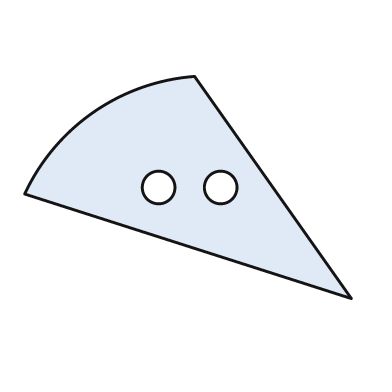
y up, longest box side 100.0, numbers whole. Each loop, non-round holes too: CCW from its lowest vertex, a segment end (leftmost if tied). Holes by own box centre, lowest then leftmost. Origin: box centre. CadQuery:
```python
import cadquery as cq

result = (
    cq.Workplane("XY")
    .moveTo(50.0, -34.0)
    .lineTo(2.0, 34.0)
    .threePointArc((-29.0, 23.0), (-50.0, -2.0))
    .close()
    .moveTo(-9.0, 0.0)
    .circle(5.0)
    .moveTo(10.0, 0.0)
    .circle(5.0)
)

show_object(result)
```